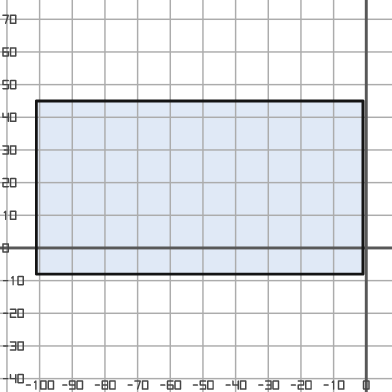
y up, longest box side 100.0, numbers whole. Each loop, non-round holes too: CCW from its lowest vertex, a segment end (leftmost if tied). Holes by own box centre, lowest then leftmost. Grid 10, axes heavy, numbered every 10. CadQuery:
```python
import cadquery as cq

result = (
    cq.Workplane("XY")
    .moveTo(-101.0, -8.0)
    .lineTo(-1.0, -8.0)
    .lineTo(-1.0, 45.0)
    .lineTo(-101.0, 45.0)
    .close()
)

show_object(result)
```